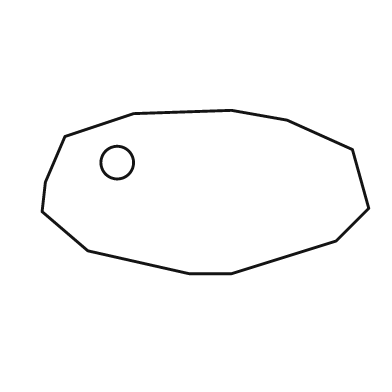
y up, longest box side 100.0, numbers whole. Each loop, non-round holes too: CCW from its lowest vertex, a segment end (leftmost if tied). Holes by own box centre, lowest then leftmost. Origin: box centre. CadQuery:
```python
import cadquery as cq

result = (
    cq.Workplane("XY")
    .moveTo(-5.0, -25.0)
    .lineTo(8.0, -25.0)
    .lineTo(40.0, -15.0)
    .lineTo(50.0, -5.0)
    .lineTo(45.0, 13.0)
    .lineTo(25.0, 22.0)
    .lineTo(8.0, 25.0)
    .lineTo(-22.0, 24.0)
    .lineTo(-43.0, 17.0)
    .lineTo(-49.0, 3.0)
    .lineTo(-50.0, -6.0)
    .lineTo(-36.0, -18.0)
    .close()
    .moveTo(-27.0, 9.0)
    .circle(5.0)
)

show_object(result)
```